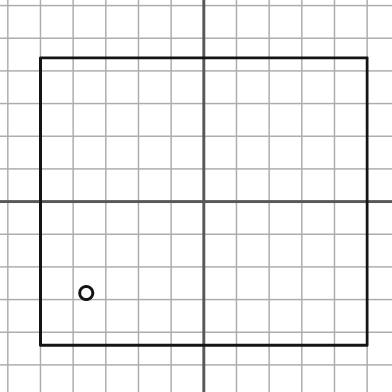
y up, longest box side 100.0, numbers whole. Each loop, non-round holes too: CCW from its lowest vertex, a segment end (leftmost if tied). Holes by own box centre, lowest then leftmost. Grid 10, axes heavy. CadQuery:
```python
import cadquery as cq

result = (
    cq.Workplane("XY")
    .moveTo(-50.0, -44.0)
    .lineTo(50.0, -44.0)
    .lineTo(50.0, 44.0)
    .lineTo(-50.0, 44.0)
    .close()
    .moveTo(-36.0, -28.0)
    .circle(2.0)
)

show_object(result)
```